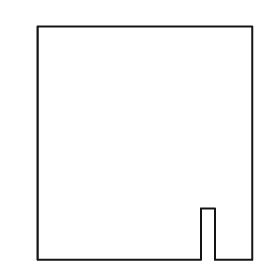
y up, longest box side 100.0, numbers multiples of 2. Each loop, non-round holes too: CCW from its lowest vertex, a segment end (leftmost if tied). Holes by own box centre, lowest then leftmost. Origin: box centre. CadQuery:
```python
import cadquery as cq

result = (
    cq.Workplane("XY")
    .moveTo(-46.0, -50.0)
    .lineTo(24.0, -50.0)
    .lineTo(24.0, -28.0)
    .lineTo(30.0, -28.0)
    .lineTo(30.0, -50.0)
    .lineTo(46.0, -50.0)
    .lineTo(46.0, 50.0)
    .lineTo(-46.0, 50.0)
    .close()
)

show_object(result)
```